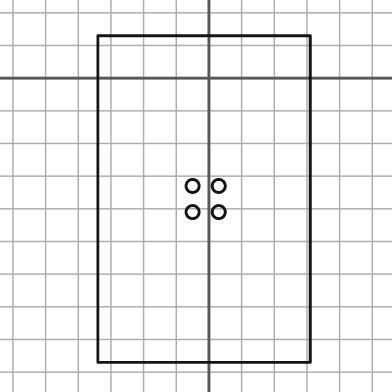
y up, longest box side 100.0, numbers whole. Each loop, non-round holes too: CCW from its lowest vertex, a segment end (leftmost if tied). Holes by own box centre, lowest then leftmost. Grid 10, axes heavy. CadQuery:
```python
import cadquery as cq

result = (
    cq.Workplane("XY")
    .moveTo(-34.0, -87.0)
    .lineTo(31.0, -87.0)
    .lineTo(31.0, 13.0)
    .lineTo(-34.0, 13.0)
    .close()
    .moveTo(-5.0, -41.0)
    .circle(2.0)
    .moveTo(3.0, -41.0)
    .circle(2.0)
    .moveTo(-5.0, -33.0)
    .circle(2.0)
    .moveTo(3.0, -33.0)
    .circle(2.0)
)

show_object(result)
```